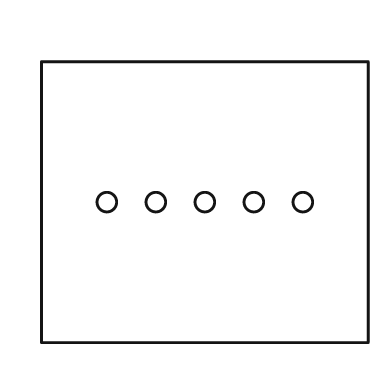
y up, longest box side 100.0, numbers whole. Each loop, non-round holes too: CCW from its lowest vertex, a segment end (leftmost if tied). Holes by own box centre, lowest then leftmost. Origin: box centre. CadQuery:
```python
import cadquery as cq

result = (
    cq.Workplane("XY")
    .moveTo(-50.0, -43.0)
    .lineTo(50.0, -43.0)
    .lineTo(50.0, 43.0)
    .lineTo(-50.0, 43.0)
    .close()
    .moveTo(-30.0, 0.0)
    .circle(3.0)
    .moveTo(-15.0, 0.0)
    .circle(3.0)
    .moveTo(0.0, 0.0)
    .circle(3.0)
    .moveTo(15.0, 0.0)
    .circle(3.0)
    .moveTo(30.0, 0.0)
    .circle(3.0)
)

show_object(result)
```